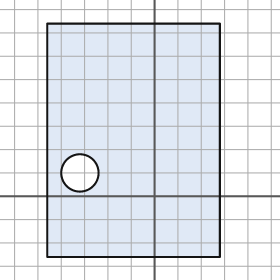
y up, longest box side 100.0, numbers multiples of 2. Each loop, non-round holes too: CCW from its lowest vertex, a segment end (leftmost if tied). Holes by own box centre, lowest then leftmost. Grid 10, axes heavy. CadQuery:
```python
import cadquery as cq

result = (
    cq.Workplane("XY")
    .moveTo(-46.0, -26.0)
    .lineTo(28.0, -26.0)
    .lineTo(28.0, 74.0)
    .lineTo(-46.0, 74.0)
    .close()
    .moveTo(-32.0, 10.0)
    .circle(8.0)
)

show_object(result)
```